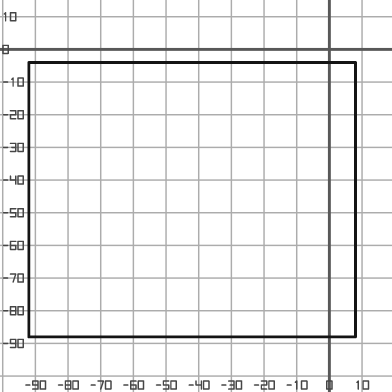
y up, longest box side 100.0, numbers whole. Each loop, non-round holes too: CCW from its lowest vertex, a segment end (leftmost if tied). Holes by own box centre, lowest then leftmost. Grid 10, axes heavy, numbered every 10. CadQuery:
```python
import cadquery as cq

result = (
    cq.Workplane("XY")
    .moveTo(-92.0, -88.0)
    .lineTo(8.0, -88.0)
    .lineTo(8.0, -4.0)
    .lineTo(-92.0, -4.0)
    .close()
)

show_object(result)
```